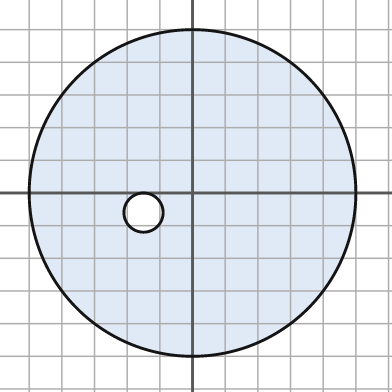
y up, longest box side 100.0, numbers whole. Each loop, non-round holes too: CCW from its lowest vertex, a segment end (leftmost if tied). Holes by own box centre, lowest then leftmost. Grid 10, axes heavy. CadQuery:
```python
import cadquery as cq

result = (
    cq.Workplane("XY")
    .moveTo(0.0, 0.0)
    .circle(50.0)
    .moveTo(-15.0, -6.0)
    .circle(6.0)
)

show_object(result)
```